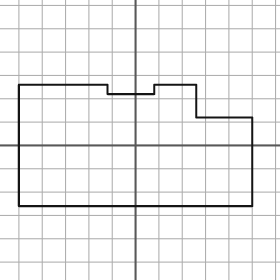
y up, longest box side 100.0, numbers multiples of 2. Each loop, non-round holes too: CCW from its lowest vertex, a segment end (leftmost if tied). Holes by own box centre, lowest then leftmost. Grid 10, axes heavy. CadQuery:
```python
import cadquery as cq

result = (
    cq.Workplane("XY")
    .moveTo(-50.0, -26.0)
    .lineTo(50.0, -26.0)
    .lineTo(50.0, 12.0)
    .lineTo(26.0, 12.0)
    .lineTo(26.0, 26.0)
    .lineTo(8.0, 26.0)
    .lineTo(8.0, 22.0)
    .lineTo(-12.0, 22.0)
    .lineTo(-12.0, 26.0)
    .lineTo(-50.0, 26.0)
    .close()
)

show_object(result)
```